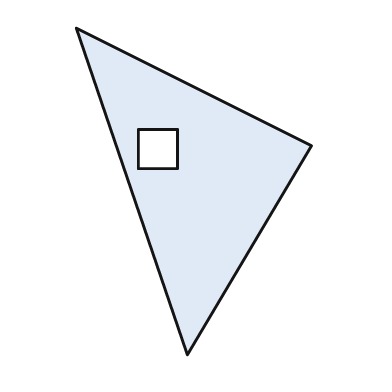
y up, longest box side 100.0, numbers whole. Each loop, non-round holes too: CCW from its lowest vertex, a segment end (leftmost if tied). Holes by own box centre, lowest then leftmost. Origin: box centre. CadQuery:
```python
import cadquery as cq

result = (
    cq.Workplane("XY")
    .moveTo(-2.0, -50.0)
    .lineTo(36.0, 14.0)
    .lineTo(-36.0, 50.0)
    .close()
    .moveTo(-17.0, 7.0)
    .lineTo(-5.0, 7.0)
    .lineTo(-5.0, 19.0)
    .lineTo(-17.0, 19.0)
    .close()
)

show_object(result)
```